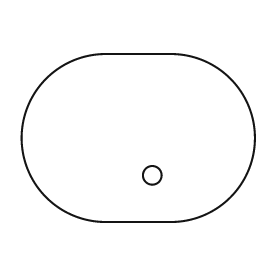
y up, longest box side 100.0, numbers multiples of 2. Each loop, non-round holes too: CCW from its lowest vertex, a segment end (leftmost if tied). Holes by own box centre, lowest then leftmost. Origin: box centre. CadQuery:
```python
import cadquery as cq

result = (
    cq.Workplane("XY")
    .moveTo(-14.0, -36.0)
    .lineTo(14.0, -36.0)
    .threePointArc((50.0, 0.0), (14.0, 36.0))
    .lineTo(-14.0, 36.0)
    .threePointArc((-50.0, 0.0), (-14.0, -36.0))
    .close()
    .moveTo(6.0, -16.0)
    .circle(4.0)
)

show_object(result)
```